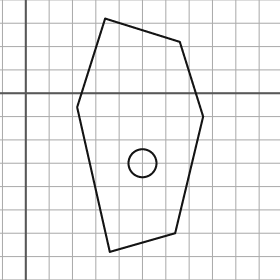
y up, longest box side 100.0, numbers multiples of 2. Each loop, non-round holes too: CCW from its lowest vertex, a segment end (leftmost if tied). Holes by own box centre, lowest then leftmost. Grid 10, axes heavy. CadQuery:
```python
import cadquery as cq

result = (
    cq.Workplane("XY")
    .moveTo(36.0, -68.0)
    .lineTo(64.0, -60.0)
    .lineTo(76.0, -10.0)
    .lineTo(66.0, 22.0)
    .lineTo(34.0, 32.0)
    .lineTo(22.0, -6.0)
    .close()
    .moveTo(50.0, -30.0)
    .circle(6.0)
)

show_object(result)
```